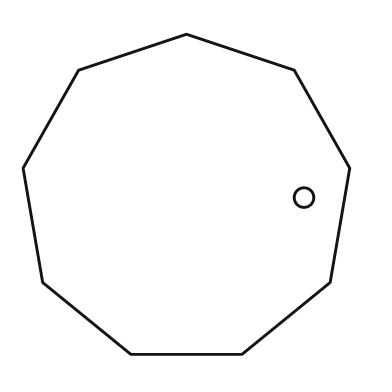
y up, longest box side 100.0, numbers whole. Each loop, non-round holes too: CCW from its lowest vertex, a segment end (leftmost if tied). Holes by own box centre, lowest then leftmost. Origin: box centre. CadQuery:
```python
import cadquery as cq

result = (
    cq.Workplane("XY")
    .moveTo(-17.0, -49.0)
    .lineTo(17.0, -49.0)
    .lineTo(44.0, -27.0)
    .lineTo(50.0, 8.0)
    .lineTo(33.0, 38.0)
    .lineTo(0.0, 49.0)
    .lineTo(-33.0, 38.0)
    .lineTo(-50.0, 8.0)
    .lineTo(-44.0, -27.0)
    .close()
    .moveTo(36.0, -1.0)
    .circle(3.0)
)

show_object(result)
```